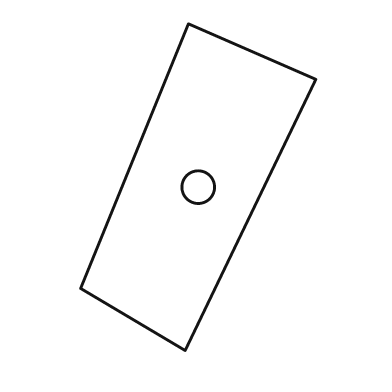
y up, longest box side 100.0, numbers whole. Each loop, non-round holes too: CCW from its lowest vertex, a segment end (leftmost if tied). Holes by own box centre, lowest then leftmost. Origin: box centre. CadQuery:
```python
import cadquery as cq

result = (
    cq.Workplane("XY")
    .moveTo(-4.0, -50.0)
    .lineTo(36.0, 33.0)
    .lineTo(-3.0, 50.0)
    .lineTo(-36.0, -31.0)
    .close()
    .moveTo(0.0, 0.0)
    .circle(5.0)
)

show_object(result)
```